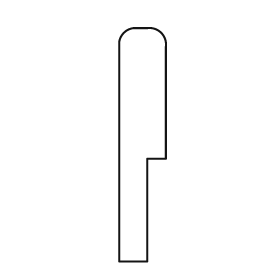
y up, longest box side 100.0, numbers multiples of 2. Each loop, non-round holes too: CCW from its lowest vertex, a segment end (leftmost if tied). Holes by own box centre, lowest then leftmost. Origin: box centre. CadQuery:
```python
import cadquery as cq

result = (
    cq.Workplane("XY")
    .moveTo(-10.0, -50.0)
    .lineTo(2.0, -50.0)
    .lineTo(2.0, -6.0)
    .lineTo(10.0, -6.0)
    .lineTo(10.0, 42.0)
    .threePointArc((8.0, 48.0), (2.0, 50.0))
    .lineTo(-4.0, 50.0)
    .threePointArc((-8.0, 48.0), (-10.0, 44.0))
    .close()
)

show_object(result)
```